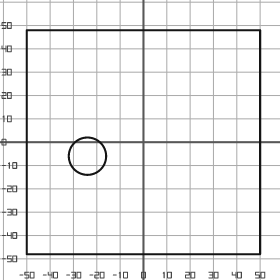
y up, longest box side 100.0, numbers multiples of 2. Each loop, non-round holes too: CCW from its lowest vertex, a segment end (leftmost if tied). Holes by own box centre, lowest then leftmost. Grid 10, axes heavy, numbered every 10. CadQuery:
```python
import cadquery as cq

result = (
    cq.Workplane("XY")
    .moveTo(-50.0, -48.0)
    .lineTo(50.0, -48.0)
    .lineTo(50.0, 48.0)
    .lineTo(-50.0, 48.0)
    .close()
    .moveTo(-24.0, -6.0)
    .circle(8.0)
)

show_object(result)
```